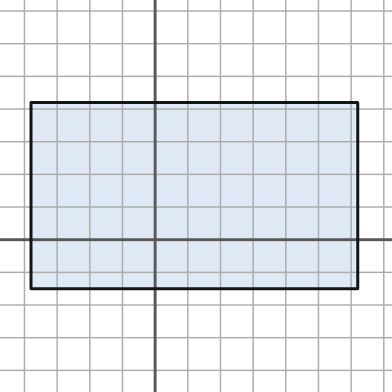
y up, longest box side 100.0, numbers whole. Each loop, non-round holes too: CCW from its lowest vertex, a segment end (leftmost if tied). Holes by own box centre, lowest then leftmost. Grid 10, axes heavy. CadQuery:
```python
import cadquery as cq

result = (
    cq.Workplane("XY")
    .moveTo(-38.0, -15.0)
    .lineTo(62.0, -15.0)
    .lineTo(62.0, 42.0)
    .lineTo(-38.0, 42.0)
    .close()
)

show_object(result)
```